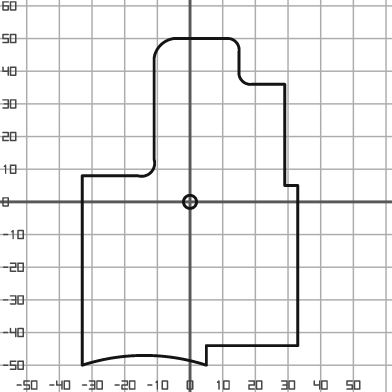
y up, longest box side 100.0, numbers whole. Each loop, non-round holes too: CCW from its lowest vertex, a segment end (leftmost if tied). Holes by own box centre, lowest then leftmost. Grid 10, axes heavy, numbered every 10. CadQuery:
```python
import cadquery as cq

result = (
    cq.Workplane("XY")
    .moveTo(-33.0, -50.0)
    .threePointArc((-14.0, -47.0), (5.0, -50.0))
    .lineTo(5.0, -44.0)
    .lineTo(33.0, -44.0)
    .lineTo(33.0, 5.0)
    .lineTo(29.0, 5.0)
    .lineTo(29.0, 36.0)
    .lineTo(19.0, 36.0)
    .threePointArc((16.0, 37.0), (15.0, 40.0))
    .lineTo(15.0, 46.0)
    .threePointArc((14.0, 49.0), (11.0, 50.0))
    .lineTo(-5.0, 50.0)
    .threePointArc((-9.0, 48.0), (-11.0, 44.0))
    .lineTo(-11.0, 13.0)
    .threePointArc((-12.0, 9.0), (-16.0, 8.0))
    .lineTo(-33.0, 8.0)
    .close()
    .moveTo(0.0, 0.0)
    .circle(2.0)
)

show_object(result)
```